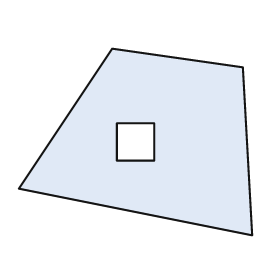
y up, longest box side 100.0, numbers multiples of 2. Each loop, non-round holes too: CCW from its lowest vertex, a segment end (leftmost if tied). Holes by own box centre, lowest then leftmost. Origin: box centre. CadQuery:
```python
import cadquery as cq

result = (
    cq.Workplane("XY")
    .moveTo(50.0, -40.0)
    .lineTo(46.0, 32.0)
    .lineTo(-10.0, 40.0)
    .lineTo(-50.0, -20.0)
    .close()
    .moveTo(-8.0, -8.0)
    .lineTo(8.0, -8.0)
    .lineTo(8.0, 8.0)
    .lineTo(-8.0, 8.0)
    .close()
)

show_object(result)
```